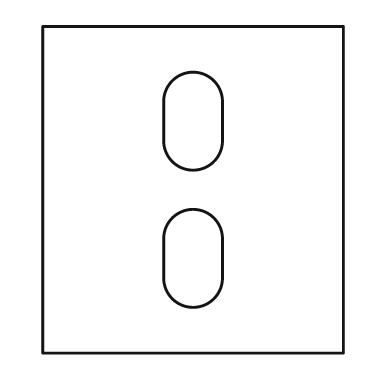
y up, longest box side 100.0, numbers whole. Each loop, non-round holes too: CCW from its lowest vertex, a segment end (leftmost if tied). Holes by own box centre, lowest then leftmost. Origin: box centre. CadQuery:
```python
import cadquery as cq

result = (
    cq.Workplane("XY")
    .moveTo(-46.0, -50.0)
    .lineTo(46.0, -50.0)
    .lineTo(46.0, 50.0)
    .lineTo(-46.0, 50.0)
    .close()
    .moveTo(-9.0, -27.0)
    .threePointArc((0.0, -36.0), (9.0, -27.0))
    .lineTo(9.0, -15.0)
    .threePointArc((0.0, -6.0), (-9.0, -15.0))
    .close()
    .moveTo(-9.0, 15.0)
    .threePointArc((0.0, 6.0), (9.0, 15.0))
    .lineTo(9.0, 27.0)
    .threePointArc((0.0, 36.0), (-9.0, 27.0))
    .close()
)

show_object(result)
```